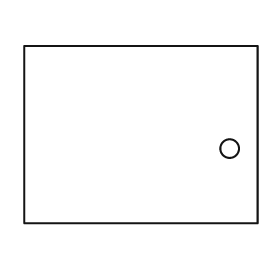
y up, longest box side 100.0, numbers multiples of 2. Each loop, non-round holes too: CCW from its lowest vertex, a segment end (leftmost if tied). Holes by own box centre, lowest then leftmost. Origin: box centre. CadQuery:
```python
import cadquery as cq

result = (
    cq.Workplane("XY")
    .moveTo(-50.0, -38.0)
    .lineTo(50.0, -38.0)
    .lineTo(50.0, 38.0)
    .lineTo(-50.0, 38.0)
    .close()
    .moveTo(38.0, -6.0)
    .circle(4.0)
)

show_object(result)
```